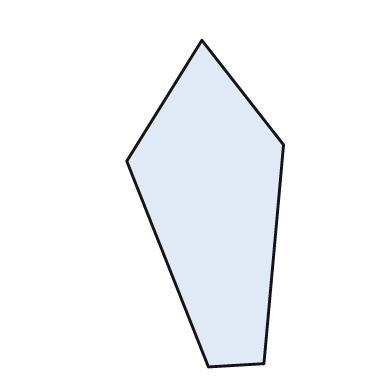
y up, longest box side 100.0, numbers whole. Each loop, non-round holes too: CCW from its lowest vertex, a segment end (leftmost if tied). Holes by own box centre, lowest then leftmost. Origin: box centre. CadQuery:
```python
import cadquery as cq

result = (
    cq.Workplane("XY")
    .moveTo(1.0, -50.0)
    .lineTo(18.0, -49.0)
    .lineTo(24.0, 18.0)
    .lineTo(-1.0, 50.0)
    .lineTo(-24.0, 13.0)
    .close()
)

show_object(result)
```